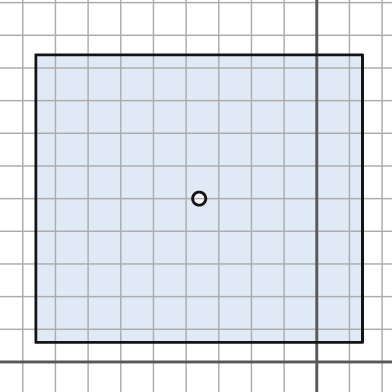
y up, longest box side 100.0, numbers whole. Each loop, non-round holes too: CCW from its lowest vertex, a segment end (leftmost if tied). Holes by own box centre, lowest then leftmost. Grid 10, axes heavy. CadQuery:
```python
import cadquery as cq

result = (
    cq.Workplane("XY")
    .moveTo(-86.0, 6.0)
    .lineTo(14.0, 6.0)
    .lineTo(14.0, 94.0)
    .lineTo(-86.0, 94.0)
    .close()
    .moveTo(-36.0, 50.0)
    .circle(2.0)
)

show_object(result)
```